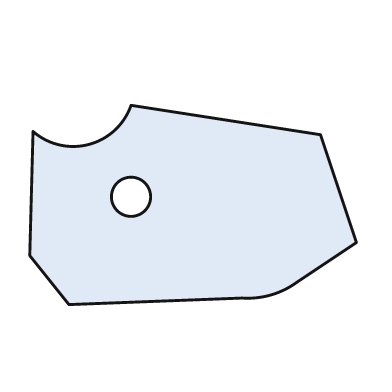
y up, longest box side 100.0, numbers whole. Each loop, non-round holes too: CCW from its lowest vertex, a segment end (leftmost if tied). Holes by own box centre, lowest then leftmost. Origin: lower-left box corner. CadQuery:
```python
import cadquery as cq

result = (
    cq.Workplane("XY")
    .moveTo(12.0, 0.0)
    .lineTo(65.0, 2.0)
    .threePointArc((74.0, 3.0), (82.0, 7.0))
    .lineTo(100.0, 19.0)
    .lineTo(89.0, 52.0)
    .lineTo(31.0, 61.0)
    .threePointArc((18.0, 49.0), (1.0, 53.0))
    .lineTo(0.0, 15.0)
    .close()
    .moveTo(31.0, 33.0)
    .circle(6.0)
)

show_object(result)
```